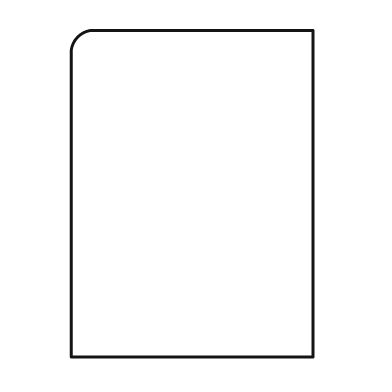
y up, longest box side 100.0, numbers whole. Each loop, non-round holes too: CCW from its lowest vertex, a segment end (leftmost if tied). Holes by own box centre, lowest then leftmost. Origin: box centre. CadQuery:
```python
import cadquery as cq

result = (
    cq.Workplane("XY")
    .moveTo(-37.0, -50.0)
    .lineTo(37.0, -50.0)
    .lineTo(37.0, 50.0)
    .lineTo(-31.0, 50.0)
    .threePointArc((-35.0, 48.0), (-37.0, 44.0))
    .close()
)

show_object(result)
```